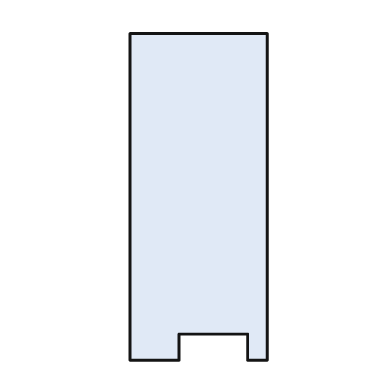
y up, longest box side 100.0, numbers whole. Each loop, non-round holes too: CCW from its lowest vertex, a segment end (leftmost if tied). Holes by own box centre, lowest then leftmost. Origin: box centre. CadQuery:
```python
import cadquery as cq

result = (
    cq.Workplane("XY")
    .moveTo(-21.0, -50.0)
    .lineTo(-6.0, -50.0)
    .lineTo(-6.0, -42.0)
    .lineTo(15.0, -42.0)
    .lineTo(15.0, -50.0)
    .lineTo(21.0, -50.0)
    .lineTo(21.0, 50.0)
    .lineTo(-21.0, 50.0)
    .close()
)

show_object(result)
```